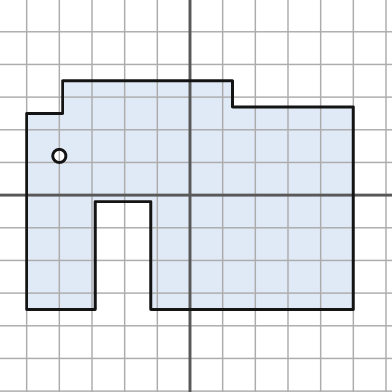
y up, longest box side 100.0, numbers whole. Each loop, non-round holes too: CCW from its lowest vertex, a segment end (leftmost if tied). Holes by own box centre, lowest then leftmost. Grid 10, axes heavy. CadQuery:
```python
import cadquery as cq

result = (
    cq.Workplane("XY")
    .moveTo(-50.0, -35.0)
    .lineTo(-29.0, -35.0)
    .lineTo(-29.0, -2.0)
    .lineTo(-12.0, -2.0)
    .lineTo(-12.0, -35.0)
    .lineTo(50.0, -35.0)
    .lineTo(50.0, 27.0)
    .lineTo(13.0, 27.0)
    .lineTo(13.0, 35.0)
    .lineTo(-39.0, 35.0)
    .lineTo(-39.0, 25.0)
    .lineTo(-50.0, 25.0)
    .close()
    .moveTo(-40.0, 12.0)
    .circle(2.0)
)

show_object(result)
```